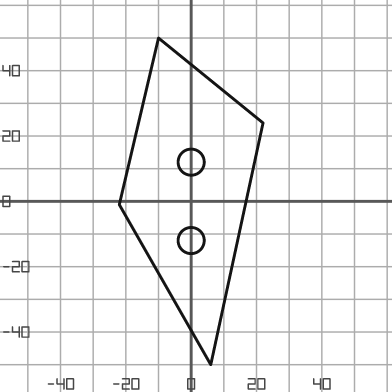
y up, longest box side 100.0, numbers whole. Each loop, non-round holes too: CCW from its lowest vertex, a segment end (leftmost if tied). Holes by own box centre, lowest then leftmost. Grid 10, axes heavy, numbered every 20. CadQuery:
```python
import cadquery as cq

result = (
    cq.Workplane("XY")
    .moveTo(6.0, -50.0)
    .lineTo(22.0, 24.0)
    .lineTo(-10.0, 50.0)
    .lineTo(-22.0, -1.0)
    .close()
    .moveTo(0.0, -12.0)
    .circle(4.0)
    .moveTo(0.0, 12.0)
    .circle(4.0)
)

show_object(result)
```